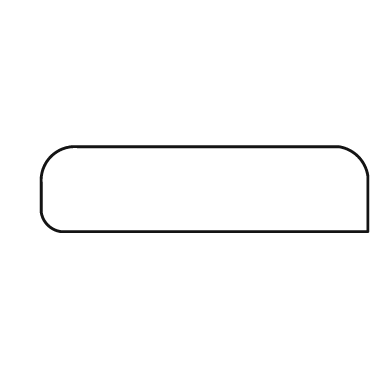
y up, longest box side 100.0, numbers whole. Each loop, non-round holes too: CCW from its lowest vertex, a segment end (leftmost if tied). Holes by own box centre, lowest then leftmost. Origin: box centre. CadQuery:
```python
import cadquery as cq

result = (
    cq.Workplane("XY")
    .moveTo(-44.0, -13.0)
    .lineTo(50.0, -13.0)
    .lineTo(50.0, 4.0)
    .threePointArc((47.0, 10.0), (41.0, 13.0))
    .lineTo(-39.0, 13.0)
    .threePointArc((-47.0, 10.0), (-50.0, 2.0))
    .lineTo(-50.0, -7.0)
    .threePointArc((-48.0, -11.0), (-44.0, -13.0))
    .close()
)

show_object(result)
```